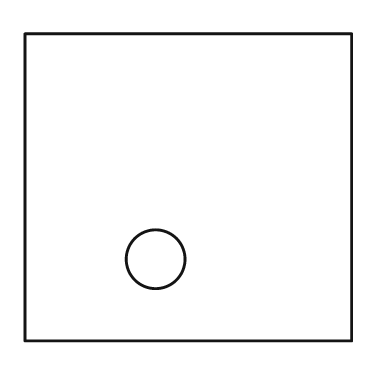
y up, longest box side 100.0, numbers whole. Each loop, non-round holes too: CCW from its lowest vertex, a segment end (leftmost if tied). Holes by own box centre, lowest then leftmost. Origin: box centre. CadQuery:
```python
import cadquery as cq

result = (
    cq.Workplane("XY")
    .moveTo(-50.0, -47.0)
    .lineTo(50.0, -47.0)
    .lineTo(50.0, 47.0)
    .lineTo(-50.0, 47.0)
    .close()
    .moveTo(-10.0, -22.0)
    .circle(9.0)
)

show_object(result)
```